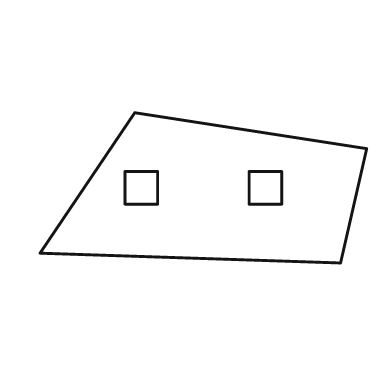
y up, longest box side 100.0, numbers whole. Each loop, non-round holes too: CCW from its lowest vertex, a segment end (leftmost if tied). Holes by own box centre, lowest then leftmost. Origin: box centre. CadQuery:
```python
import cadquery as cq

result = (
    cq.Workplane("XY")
    .moveTo(42.0, -23.0)
    .lineTo(50.0, 12.0)
    .lineTo(-21.0, 23.0)
    .lineTo(-50.0, -20.0)
    .close()
    .moveTo(-24.0, -5.0)
    .lineTo(-14.0, -5.0)
    .lineTo(-14.0, 5.0)
    .lineTo(-24.0, 5.0)
    .close()
    .moveTo(14.0, -5.0)
    .lineTo(24.0, -5.0)
    .lineTo(24.0, 5.0)
    .lineTo(14.0, 5.0)
    .close()
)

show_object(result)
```